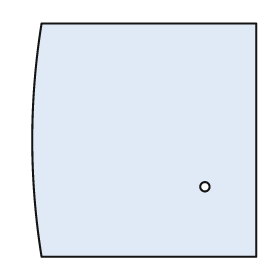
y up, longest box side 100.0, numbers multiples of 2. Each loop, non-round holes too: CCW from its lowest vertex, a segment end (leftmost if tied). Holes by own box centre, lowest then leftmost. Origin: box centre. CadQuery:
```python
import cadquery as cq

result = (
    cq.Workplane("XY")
    .moveTo(-44.0, -50.0)
    .lineTo(48.0, -50.0)
    .lineTo(48.0, 50.0)
    .lineTo(-44.0, 50.0)
    .threePointArc((-48.0, 0.0), (-44.0, -50.0))
    .close()
    .moveTo(26.0, -20.0)
    .circle(2.0)
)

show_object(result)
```